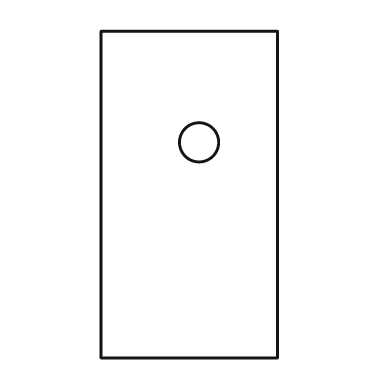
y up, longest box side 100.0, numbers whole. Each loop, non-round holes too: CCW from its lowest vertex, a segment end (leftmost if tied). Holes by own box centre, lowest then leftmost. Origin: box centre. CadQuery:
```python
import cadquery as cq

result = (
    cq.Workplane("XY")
    .moveTo(-27.0, -50.0)
    .lineTo(27.0, -50.0)
    .lineTo(27.0, 50.0)
    .lineTo(-27.0, 50.0)
    .close()
    .moveTo(3.0, 16.0)
    .circle(6.0)
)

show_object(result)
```